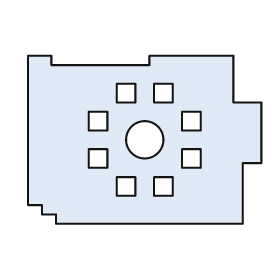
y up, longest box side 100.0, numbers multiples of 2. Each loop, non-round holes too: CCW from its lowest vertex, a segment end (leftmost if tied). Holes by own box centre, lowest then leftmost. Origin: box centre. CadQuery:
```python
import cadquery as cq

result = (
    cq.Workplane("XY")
    .moveTo(-38.0, -36.0)
    .lineTo(42.0, -36.0)
    .lineTo(42.0, -10.0)
    .lineTo(50.0, -10.0)
    .lineTo(50.0, 16.0)
    .lineTo(38.0, 16.0)
    .lineTo(38.0, 36.0)
    .lineTo(2.0, 36.0)
    .lineTo(2.0, 32.0)
    .lineTo(-40.0, 32.0)
    .lineTo(-40.0, 36.0)
    .lineTo(-50.0, 36.0)
    .lineTo(-50.0, -28.0)
    .lineTo(-44.0, -28.0)
    .lineTo(-44.0, -32.0)
    .lineTo(-38.0, -32.0)
    .close()
    .moveTo(-12.0, -24.0)
    .lineTo(-4.0, -24.0)
    .lineTo(-4.0, -16.0)
    .lineTo(-12.0, -16.0)
    .close()
    .moveTo(4.0, -24.0)
    .lineTo(12.0, -24.0)
    .lineTo(12.0, -16.0)
    .lineTo(4.0, -16.0)
    .close()
    .moveTo(-24.0, -12.0)
    .lineTo(-16.0, -12.0)
    .lineTo(-16.0, -4.0)
    .lineTo(-24.0, -4.0)
    .close()
    .moveTo(16.0, -12.0)
    .lineTo(24.0, -12.0)
    .lineTo(24.0, -4.0)
    .lineTo(16.0, -4.0)
    .close()
    .moveTo(0.0, 0.0)
    .circle(8.0)
    .moveTo(-24.0, 4.0)
    .lineTo(-16.0, 4.0)
    .lineTo(-16.0, 12.0)
    .lineTo(-24.0, 12.0)
    .close()
    .moveTo(16.0, 4.0)
    .lineTo(24.0, 4.0)
    .lineTo(24.0, 12.0)
    .lineTo(16.0, 12.0)
    .close()
    .moveTo(-12.0, 16.0)
    .lineTo(-4.0, 16.0)
    .lineTo(-4.0, 24.0)
    .lineTo(-12.0, 24.0)
    .close()
    .moveTo(4.0, 16.0)
    .lineTo(12.0, 16.0)
    .lineTo(12.0, 24.0)
    .lineTo(4.0, 24.0)
    .close()
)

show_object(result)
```